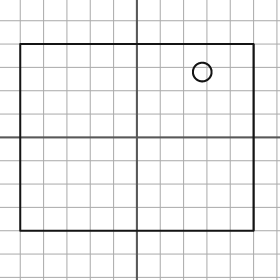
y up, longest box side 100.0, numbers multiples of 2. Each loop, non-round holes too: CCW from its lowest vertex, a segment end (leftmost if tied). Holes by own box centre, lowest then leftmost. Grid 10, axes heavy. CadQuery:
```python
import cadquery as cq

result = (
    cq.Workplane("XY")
    .moveTo(-50.0, -40.0)
    .lineTo(50.0, -40.0)
    .lineTo(50.0, 40.0)
    .lineTo(-50.0, 40.0)
    .close()
    .moveTo(28.0, 28.0)
    .circle(4.0)
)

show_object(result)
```